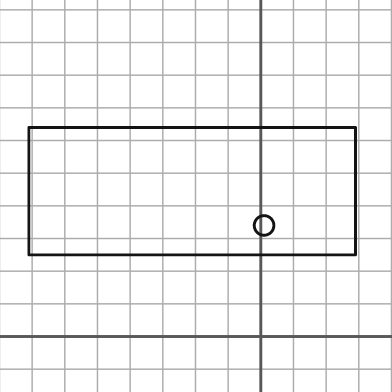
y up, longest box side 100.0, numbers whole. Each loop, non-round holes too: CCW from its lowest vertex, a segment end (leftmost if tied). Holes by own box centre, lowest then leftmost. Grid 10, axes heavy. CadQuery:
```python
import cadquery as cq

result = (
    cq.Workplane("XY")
    .moveTo(-71.0, 25.0)
    .lineTo(29.0, 25.0)
    .lineTo(29.0, 64.0)
    .lineTo(-71.0, 64.0)
    .close()
    .moveTo(1.0, 34.0)
    .circle(3.0)
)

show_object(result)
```